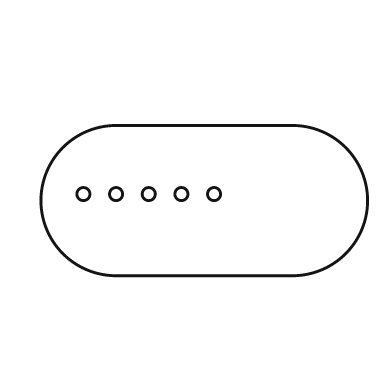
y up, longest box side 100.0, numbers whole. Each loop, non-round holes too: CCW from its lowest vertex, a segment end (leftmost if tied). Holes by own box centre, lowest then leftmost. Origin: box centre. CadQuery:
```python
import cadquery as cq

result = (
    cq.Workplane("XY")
    .moveTo(-27.0, -23.0)
    .lineTo(27.0, -23.0)
    .threePointArc((50.0, 0.0), (27.0, 23.0))
    .lineTo(-27.0, 23.0)
    .threePointArc((-50.0, 0.0), (-27.0, -23.0))
    .close()
    .moveTo(-37.0, 2.0)
    .circle(2.0)
    .moveTo(-27.0, 2.0)
    .circle(2.0)
    .moveTo(-17.0, 2.0)
    .circle(2.0)
    .moveTo(-7.0, 2.0)
    .circle(2.0)
    .moveTo(3.0, 2.0)
    .circle(2.0)
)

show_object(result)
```